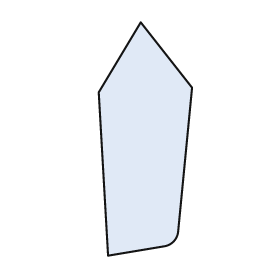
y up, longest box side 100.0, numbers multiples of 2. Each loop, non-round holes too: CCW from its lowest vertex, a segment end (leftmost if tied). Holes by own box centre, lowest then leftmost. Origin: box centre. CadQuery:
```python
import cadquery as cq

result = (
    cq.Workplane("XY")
    .moveTo(-16.0, -50.0)
    .lineTo(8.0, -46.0)
    .threePointArc((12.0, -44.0), (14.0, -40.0))
    .lineTo(20.0, 22.0)
    .lineTo(-2.0, 50.0)
    .lineTo(-20.0, 20.0)
    .close()
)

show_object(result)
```